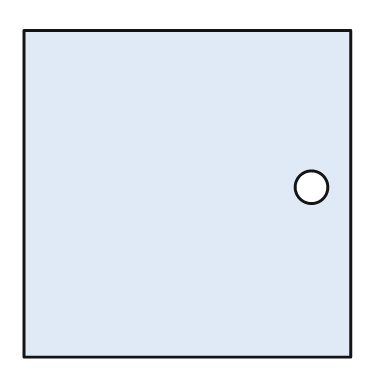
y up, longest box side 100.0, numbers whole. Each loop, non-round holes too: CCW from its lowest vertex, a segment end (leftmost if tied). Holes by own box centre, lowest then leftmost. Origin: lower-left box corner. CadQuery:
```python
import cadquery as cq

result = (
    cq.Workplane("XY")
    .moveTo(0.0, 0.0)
    .lineTo(100.0, 0.0)
    .lineTo(100.0, 100.0)
    .lineTo(0.0, 100.0)
    .close()
    .moveTo(88.0, 52.0)
    .circle(5.0)
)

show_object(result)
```